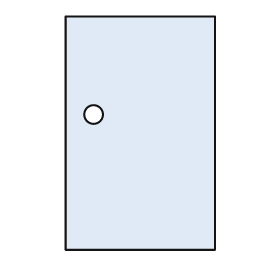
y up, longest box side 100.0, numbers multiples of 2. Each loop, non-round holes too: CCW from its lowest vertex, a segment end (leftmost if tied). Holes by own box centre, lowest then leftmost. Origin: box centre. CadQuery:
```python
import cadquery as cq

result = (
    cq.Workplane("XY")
    .moveTo(-32.0, -50.0)
    .lineTo(32.0, -50.0)
    .lineTo(32.0, 50.0)
    .lineTo(-32.0, 50.0)
    .close()
    .moveTo(-20.0, 8.0)
    .circle(4.0)
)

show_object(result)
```